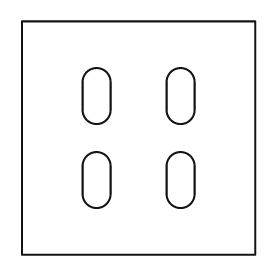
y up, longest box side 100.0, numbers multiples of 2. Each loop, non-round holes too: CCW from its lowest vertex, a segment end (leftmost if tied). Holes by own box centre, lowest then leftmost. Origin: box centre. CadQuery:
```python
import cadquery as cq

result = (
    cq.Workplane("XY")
    .moveTo(-50.0, -50.0)
    .lineTo(50.0, -50.0)
    .lineTo(50.0, 50.0)
    .lineTo(-50.0, 50.0)
    .close()
    .moveTo(-24.0, -24.0)
    .threePointArc((-18.0, -30.0), (-12.0, -24.0))
    .lineTo(-12.0, -12.0)
    .threePointArc((-18.0, -6.0), (-24.0, -12.0))
    .close()
    .moveTo(12.0, -24.0)
    .threePointArc((18.0, -30.0), (24.0, -24.0))
    .lineTo(24.0, -12.0)
    .threePointArc((18.0, -6.0), (12.0, -12.0))
    .close()
    .moveTo(-24.0, 12.0)
    .threePointArc((-18.0, 6.0), (-12.0, 12.0))
    .lineTo(-12.0, 24.0)
    .threePointArc((-18.0, 30.0), (-24.0, 24.0))
    .close()
    .moveTo(12.0, 12.0)
    .threePointArc((18.0, 6.0), (24.0, 12.0))
    .lineTo(24.0, 24.0)
    .threePointArc((18.0, 30.0), (12.0, 24.0))
    .close()
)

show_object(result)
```